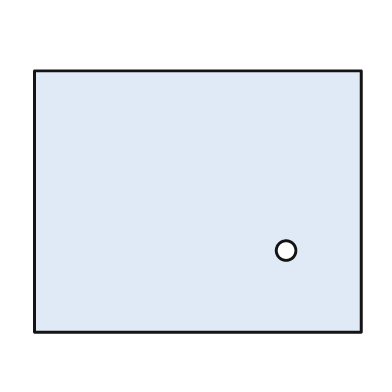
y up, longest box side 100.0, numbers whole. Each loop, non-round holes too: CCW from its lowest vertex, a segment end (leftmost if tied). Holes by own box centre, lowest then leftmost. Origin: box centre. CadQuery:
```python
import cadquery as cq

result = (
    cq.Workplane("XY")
    .moveTo(-50.0, -40.0)
    .lineTo(50.0, -40.0)
    .lineTo(50.0, 40.0)
    .lineTo(-50.0, 40.0)
    .close()
    .moveTo(27.0, -15.0)
    .circle(3.0)
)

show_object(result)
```